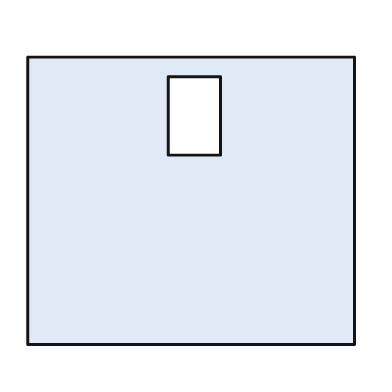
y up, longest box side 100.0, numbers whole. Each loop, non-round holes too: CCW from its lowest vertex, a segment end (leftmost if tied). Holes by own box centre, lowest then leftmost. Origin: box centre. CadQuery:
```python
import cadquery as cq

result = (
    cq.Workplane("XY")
    .moveTo(-50.0, -44.0)
    .lineTo(50.0, -44.0)
    .lineTo(50.0, 44.0)
    .lineTo(-50.0, 44.0)
    .close()
    .moveTo(-7.0, 14.0)
    .lineTo(9.0, 14.0)
    .lineTo(9.0, 38.0)
    .lineTo(-7.0, 38.0)
    .close()
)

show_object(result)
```